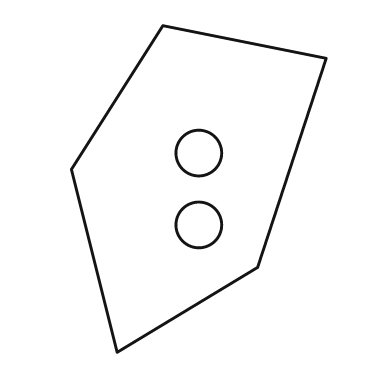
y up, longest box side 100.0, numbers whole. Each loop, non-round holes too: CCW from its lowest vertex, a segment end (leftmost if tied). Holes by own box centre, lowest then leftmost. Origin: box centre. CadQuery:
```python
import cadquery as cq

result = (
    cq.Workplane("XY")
    .moveTo(-25.0, -50.0)
    .lineTo(18.0, -24.0)
    .lineTo(39.0, 40.0)
    .lineTo(-11.0, 50.0)
    .lineTo(-39.0, 6.0)
    .close()
    .moveTo(0.0, -11.0)
    .circle(7.0)
    .moveTo(0.0, 11.0)
    .circle(7.0)
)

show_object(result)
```